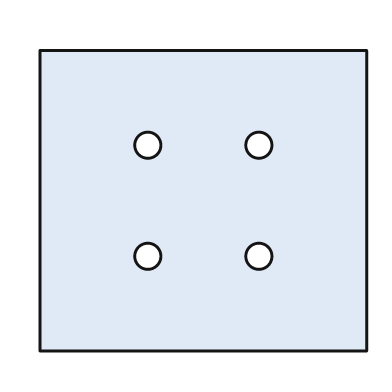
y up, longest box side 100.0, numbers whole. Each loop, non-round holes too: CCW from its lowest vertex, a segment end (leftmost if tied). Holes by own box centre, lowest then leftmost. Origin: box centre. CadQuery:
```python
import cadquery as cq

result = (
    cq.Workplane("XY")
    .moveTo(-50.0, -46.0)
    .lineTo(50.0, -46.0)
    .lineTo(50.0, 46.0)
    .lineTo(-50.0, 46.0)
    .close()
    .moveTo(-17.0, -17.0)
    .circle(4.0)
    .moveTo(17.0, -17.0)
    .circle(4.0)
    .moveTo(-17.0, 17.0)
    .circle(4.0)
    .moveTo(17.0, 17.0)
    .circle(4.0)
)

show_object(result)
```